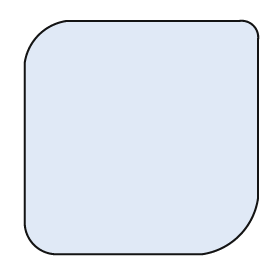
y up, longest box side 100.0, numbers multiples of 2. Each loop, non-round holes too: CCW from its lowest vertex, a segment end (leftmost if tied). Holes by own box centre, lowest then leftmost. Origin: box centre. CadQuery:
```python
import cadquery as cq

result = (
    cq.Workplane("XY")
    .moveTo(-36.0, -50.0)
    .lineTo(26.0, -50.0)
    .threePointArc((42.0, -42.0), (50.0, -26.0))
    .lineTo(50.0, 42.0)
    .threePointArc((48.0, 48.0), (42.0, 50.0))
    .lineTo(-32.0, 50.0)
    .threePointArc((-44.0, 44.0), (-50.0, 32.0))
    .lineTo(-50.0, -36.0)
    .threePointArc((-46.0, -46.0), (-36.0, -50.0))
    .close()
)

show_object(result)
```